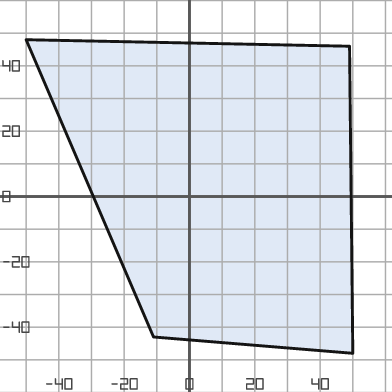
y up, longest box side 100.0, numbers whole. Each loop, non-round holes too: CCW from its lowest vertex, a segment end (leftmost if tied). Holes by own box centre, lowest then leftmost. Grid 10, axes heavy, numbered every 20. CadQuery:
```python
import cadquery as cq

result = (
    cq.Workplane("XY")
    .moveTo(50.0, -48.0)
    .lineTo(49.0, 46.0)
    .lineTo(-50.0, 48.0)
    .lineTo(-11.0, -43.0)
    .close()
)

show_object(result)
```